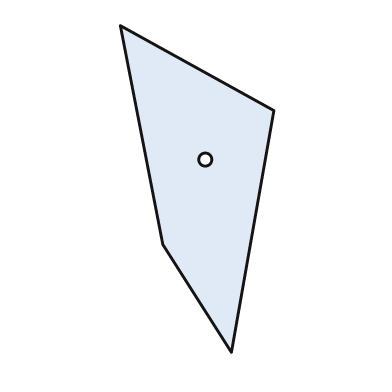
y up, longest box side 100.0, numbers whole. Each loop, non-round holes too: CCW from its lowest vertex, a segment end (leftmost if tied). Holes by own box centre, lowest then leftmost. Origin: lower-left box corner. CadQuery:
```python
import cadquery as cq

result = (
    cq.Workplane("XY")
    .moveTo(34.0, 0.0)
    .lineTo(47.0, 74.0)
    .lineTo(0.0, 100.0)
    .lineTo(13.0, 33.0)
    .close()
    .moveTo(26.0, 59.0)
    .circle(2.0)
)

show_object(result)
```